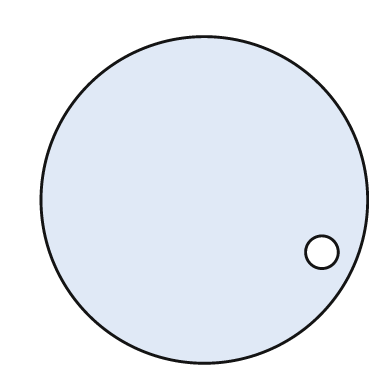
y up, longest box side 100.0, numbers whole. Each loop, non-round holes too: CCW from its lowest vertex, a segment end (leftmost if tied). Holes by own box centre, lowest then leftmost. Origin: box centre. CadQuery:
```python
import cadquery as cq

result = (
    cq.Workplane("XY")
    .moveTo(0.0, 0.0)
    .circle(50.0)
    .moveTo(36.0, -16.0)
    .circle(5.0)
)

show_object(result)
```